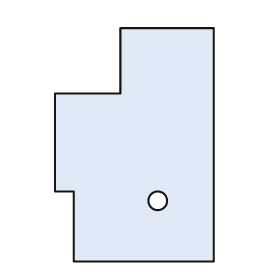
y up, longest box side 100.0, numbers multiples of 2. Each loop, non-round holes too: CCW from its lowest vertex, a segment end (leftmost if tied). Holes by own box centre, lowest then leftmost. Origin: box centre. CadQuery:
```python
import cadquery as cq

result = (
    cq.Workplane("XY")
    .moveTo(-26.0, -50.0)
    .lineTo(34.0, -50.0)
    .lineTo(34.0, 50.0)
    .lineTo(-6.0, 50.0)
    .lineTo(-6.0, 22.0)
    .lineTo(-34.0, 22.0)
    .lineTo(-34.0, -20.0)
    .lineTo(-26.0, -20.0)
    .close()
    .moveTo(10.0, -24.0)
    .circle(4.0)
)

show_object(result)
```